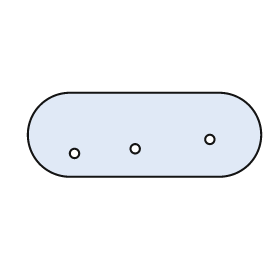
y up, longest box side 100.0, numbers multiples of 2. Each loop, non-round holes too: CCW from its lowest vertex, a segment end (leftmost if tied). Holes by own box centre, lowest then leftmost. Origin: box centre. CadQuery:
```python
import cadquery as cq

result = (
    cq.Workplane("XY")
    .moveTo(-32.0, -18.0)
    .lineTo(32.0, -18.0)
    .threePointArc((50.0, 0.0), (32.0, 18.0))
    .lineTo(-32.0, 18.0)
    .threePointArc((-50.0, 0.0), (-32.0, -18.0))
    .close()
    .moveTo(-30.0, -8.0)
    .circle(2.0)
    .moveTo(-4.0, -6.0)
    .circle(2.0)
    .moveTo(28.0, -2.0)
    .circle(2.0)
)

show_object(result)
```